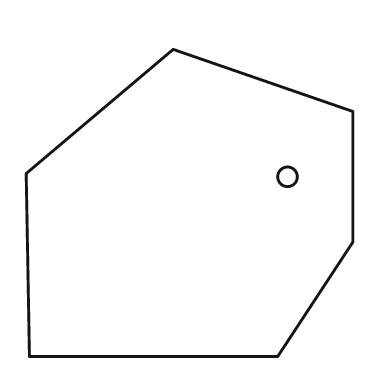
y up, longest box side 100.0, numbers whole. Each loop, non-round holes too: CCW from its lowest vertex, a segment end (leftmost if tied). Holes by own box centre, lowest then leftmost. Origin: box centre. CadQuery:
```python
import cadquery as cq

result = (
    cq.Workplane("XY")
    .moveTo(-49.0, -47.0)
    .lineTo(27.0, -47.0)
    .lineTo(50.0, -12.0)
    .lineTo(50.0, 28.0)
    .lineTo(-5.0, 47.0)
    .lineTo(-50.0, 9.0)
    .close()
    .moveTo(30.0, 8.0)
    .circle(3.0)
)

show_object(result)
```